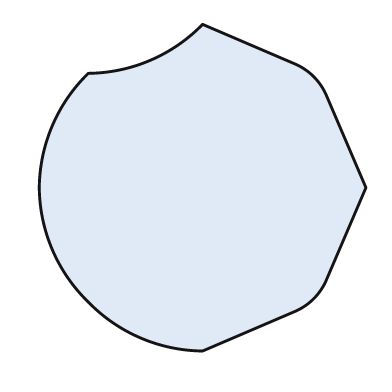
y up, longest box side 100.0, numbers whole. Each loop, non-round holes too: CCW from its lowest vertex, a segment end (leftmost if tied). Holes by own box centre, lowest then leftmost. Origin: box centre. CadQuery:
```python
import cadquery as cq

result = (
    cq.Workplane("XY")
    .moveTo(0.0, -50.0)
    .lineTo(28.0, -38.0)
    .threePointArc((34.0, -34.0), (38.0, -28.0))
    .lineTo(50.0, 0.0)
    .lineTo(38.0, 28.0)
    .threePointArc((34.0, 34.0), (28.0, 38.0))
    .lineTo(0.0, 50.0)
    .threePointArc((-16.0, 39.0), (-35.0, 35.0))
    .threePointArc((-46.0, 19.0), (-50.0, 0.0))
    .threePointArc((-46.0, -19.0), (-35.0, -35.0))
    .threePointArc((-19.0, -46.0), (0.0, -50.0))
    .close()
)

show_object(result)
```